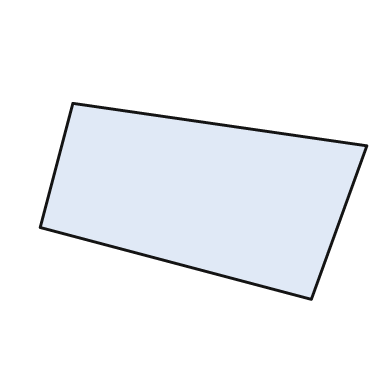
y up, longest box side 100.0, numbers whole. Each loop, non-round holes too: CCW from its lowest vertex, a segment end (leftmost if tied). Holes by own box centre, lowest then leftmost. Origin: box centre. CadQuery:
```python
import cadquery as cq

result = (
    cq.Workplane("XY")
    .moveTo(33.0, -30.0)
    .lineTo(50.0, 17.0)
    .lineTo(-40.0, 30.0)
    .lineTo(-50.0, -8.0)
    .close()
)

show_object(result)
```